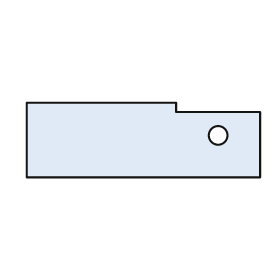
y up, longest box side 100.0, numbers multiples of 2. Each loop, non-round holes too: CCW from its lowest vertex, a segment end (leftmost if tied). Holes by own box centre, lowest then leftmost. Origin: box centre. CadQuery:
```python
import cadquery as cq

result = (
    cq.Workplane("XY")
    .moveTo(-50.0, -16.0)
    .lineTo(50.0, -16.0)
    .lineTo(50.0, 12.0)
    .lineTo(14.0, 12.0)
    .lineTo(14.0, 16.0)
    .lineTo(-50.0, 16.0)
    .close()
    .moveTo(32.0, 2.0)
    .circle(4.0)
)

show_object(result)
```